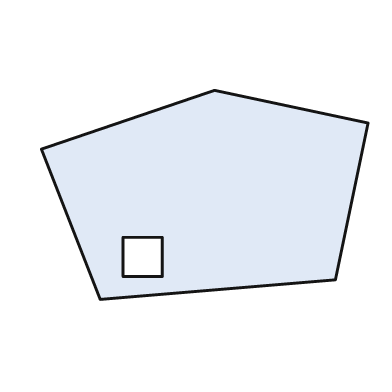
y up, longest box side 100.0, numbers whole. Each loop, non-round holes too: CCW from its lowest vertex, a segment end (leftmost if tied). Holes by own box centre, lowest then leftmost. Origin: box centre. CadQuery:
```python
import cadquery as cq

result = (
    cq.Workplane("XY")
    .moveTo(-32.0, -32.0)
    .lineTo(40.0, -26.0)
    .lineTo(50.0, 22.0)
    .lineTo(3.0, 32.0)
    .lineTo(-50.0, 14.0)
    .close()
    .moveTo(-25.0, -25.0)
    .lineTo(-13.0, -25.0)
    .lineTo(-13.0, -13.0)
    .lineTo(-25.0, -13.0)
    .close()
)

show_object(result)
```